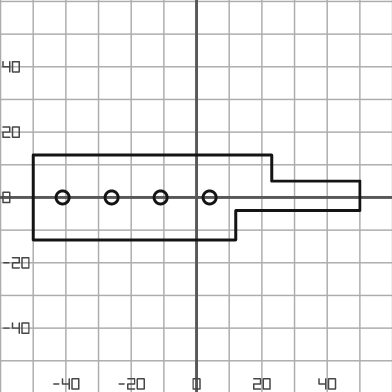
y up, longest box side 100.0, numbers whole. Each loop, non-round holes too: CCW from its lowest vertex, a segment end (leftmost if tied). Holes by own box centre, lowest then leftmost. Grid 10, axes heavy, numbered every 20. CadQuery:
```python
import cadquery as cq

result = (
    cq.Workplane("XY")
    .moveTo(-50.0, -13.0)
    .lineTo(12.0, -13.0)
    .lineTo(12.0, -4.0)
    .lineTo(50.0, -4.0)
    .lineTo(50.0, 5.0)
    .lineTo(23.0, 5.0)
    .lineTo(23.0, 13.0)
    .lineTo(-50.0, 13.0)
    .close()
    .moveTo(-41.0, 0.0)
    .circle(2.0)
    .moveTo(-26.0, 0.0)
    .circle(2.0)
    .moveTo(-11.0, 0.0)
    .circle(2.0)
    .moveTo(4.0, 0.0)
    .circle(2.0)
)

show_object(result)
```